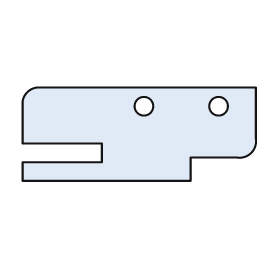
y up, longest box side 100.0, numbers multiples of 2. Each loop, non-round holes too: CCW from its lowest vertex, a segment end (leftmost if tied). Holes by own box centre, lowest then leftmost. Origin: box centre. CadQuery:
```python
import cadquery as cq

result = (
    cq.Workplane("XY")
    .moveTo(-50.0, -20.0)
    .lineTo(22.0, -20.0)
    .lineTo(22.0, -10.0)
    .lineTo(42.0, -10.0)
    .threePointArc((48.0, -8.0), (50.0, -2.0))
    .lineTo(50.0, 20.0)
    .lineTo(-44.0, 20.0)
    .threePointArc((-48.0, 18.0), (-50.0, 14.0))
    .lineTo(-50.0, -4.0)
    .lineTo(-16.0, -4.0)
    .lineTo(-16.0, -12.0)
    .lineTo(-50.0, -12.0)
    .close()
    .moveTo(2.0, 12.0)
    .circle(4.0)
    .moveTo(34.0, 12.0)
    .circle(4.0)
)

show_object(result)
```